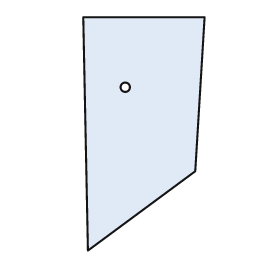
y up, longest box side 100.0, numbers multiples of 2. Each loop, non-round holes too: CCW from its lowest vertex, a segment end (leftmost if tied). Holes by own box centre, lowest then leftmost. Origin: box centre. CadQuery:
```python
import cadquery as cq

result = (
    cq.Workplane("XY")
    .moveTo(-24.0, -50.0)
    .lineTo(22.0, -16.0)
    .lineTo(26.0, 50.0)
    .lineTo(-26.0, 50.0)
    .close()
    .moveTo(-8.0, 20.0)
    .circle(2.0)
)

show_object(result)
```